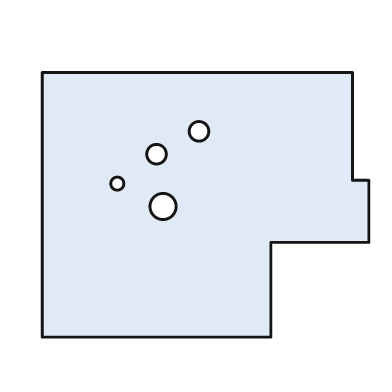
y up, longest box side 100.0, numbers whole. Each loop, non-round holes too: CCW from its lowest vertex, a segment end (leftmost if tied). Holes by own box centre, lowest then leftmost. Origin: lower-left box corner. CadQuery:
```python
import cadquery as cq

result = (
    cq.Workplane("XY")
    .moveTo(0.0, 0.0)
    .lineTo(70.0, 0.0)
    .lineTo(70.0, 29.0)
    .lineTo(100.0, 29.0)
    .lineTo(100.0, 48.0)
    .lineTo(95.0, 48.0)
    .lineTo(95.0, 81.0)
    .lineTo(0.0, 81.0)
    .close()
    .moveTo(37.0, 40.0)
    .circle(4.0)
    .moveTo(23.0, 47.0)
    .circle(2.0)
    .moveTo(35.0, 56.0)
    .circle(3.0)
    .moveTo(48.0, 63.0)
    .circle(3.0)
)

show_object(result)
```